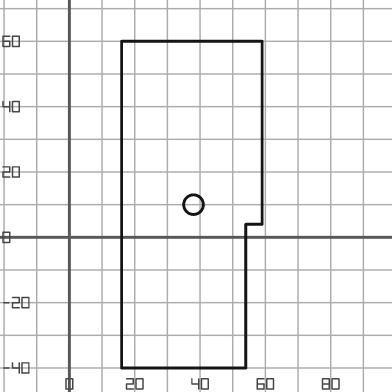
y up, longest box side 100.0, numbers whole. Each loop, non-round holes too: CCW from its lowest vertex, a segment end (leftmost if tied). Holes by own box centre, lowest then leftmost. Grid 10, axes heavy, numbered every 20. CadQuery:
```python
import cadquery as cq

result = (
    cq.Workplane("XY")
    .moveTo(16.0, -40.0)
    .lineTo(54.0, -40.0)
    .lineTo(54.0, 4.0)
    .lineTo(59.0, 4.0)
    .lineTo(59.0, 60.0)
    .lineTo(16.0, 60.0)
    .close()
    .moveTo(38.0, 10.0)
    .circle(3.0)
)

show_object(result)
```